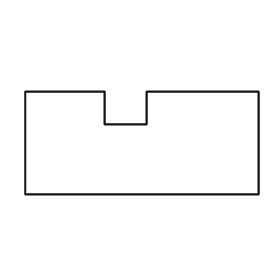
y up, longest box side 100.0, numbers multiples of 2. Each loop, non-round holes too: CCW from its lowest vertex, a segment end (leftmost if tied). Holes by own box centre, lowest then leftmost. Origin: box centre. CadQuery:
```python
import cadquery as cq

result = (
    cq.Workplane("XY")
    .moveTo(-50.0, -22.0)
    .lineTo(50.0, -22.0)
    .lineTo(50.0, 22.0)
    .lineTo(2.0, 22.0)
    .lineTo(2.0, 8.0)
    .lineTo(-16.0, 8.0)
    .lineTo(-16.0, 22.0)
    .lineTo(-50.0, 22.0)
    .close()
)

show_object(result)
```